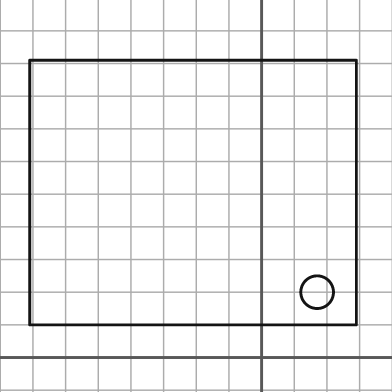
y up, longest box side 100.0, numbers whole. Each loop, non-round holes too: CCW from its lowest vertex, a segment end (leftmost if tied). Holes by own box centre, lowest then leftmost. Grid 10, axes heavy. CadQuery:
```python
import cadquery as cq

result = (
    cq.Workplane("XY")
    .moveTo(-71.0, 10.0)
    .lineTo(29.0, 10.0)
    .lineTo(29.0, 91.0)
    .lineTo(-71.0, 91.0)
    .close()
    .moveTo(17.0, 20.0)
    .circle(5.0)
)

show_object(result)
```